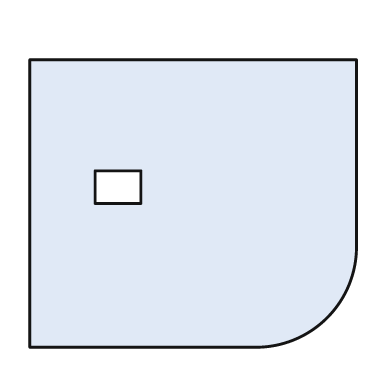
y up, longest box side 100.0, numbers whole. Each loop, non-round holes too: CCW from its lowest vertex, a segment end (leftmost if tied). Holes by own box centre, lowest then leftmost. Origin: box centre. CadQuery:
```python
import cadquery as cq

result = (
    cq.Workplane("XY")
    .moveTo(-50.0, -44.0)
    .lineTo(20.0, -44.0)
    .threePointArc((41.0, -35.0), (50.0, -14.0))
    .lineTo(50.0, 44.0)
    .lineTo(-50.0, 44.0)
    .close()
    .moveTo(-30.0, 0.0)
    .lineTo(-16.0, 0.0)
    .lineTo(-16.0, 10.0)
    .lineTo(-30.0, 10.0)
    .close()
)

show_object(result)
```